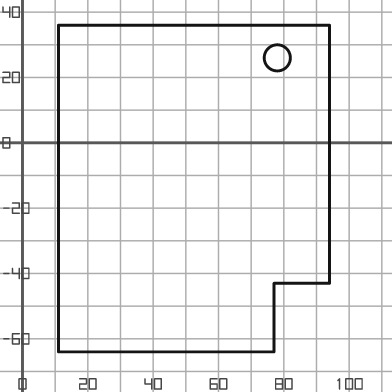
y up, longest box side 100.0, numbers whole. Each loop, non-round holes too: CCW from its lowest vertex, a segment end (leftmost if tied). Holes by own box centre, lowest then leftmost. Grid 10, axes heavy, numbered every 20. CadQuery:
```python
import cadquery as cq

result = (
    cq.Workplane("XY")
    .moveTo(11.0, -64.0)
    .lineTo(77.0, -64.0)
    .lineTo(77.0, -43.0)
    .lineTo(94.0, -43.0)
    .lineTo(94.0, 36.0)
    .lineTo(11.0, 36.0)
    .close()
    .moveTo(78.0, 26.0)
    .circle(4.0)
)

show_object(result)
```